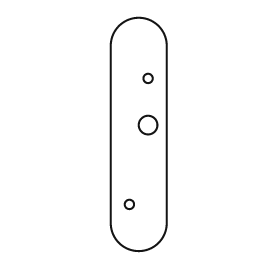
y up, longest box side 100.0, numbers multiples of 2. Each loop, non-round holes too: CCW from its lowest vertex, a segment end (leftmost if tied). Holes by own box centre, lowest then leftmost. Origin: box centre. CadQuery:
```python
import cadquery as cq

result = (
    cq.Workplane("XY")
    .moveTo(-12.0, -38.0)
    .threePointArc((0.0, -50.0), (12.0, -38.0))
    .lineTo(12.0, 38.0)
    .threePointArc((0.0, 50.0), (-12.0, 38.0))
    .close()
    .moveTo(-4.0, -30.0)
    .circle(2.0)
    .moveTo(4.0, 4.0)
    .circle(4.0)
    .moveTo(4.0, 24.0)
    .circle(2.0)
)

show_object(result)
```